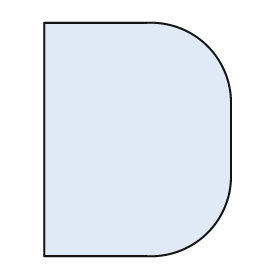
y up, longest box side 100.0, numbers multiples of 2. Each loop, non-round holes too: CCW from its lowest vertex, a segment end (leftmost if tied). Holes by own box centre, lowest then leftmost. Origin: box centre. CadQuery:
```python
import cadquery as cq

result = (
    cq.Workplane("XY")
    .moveTo(-40.0, -50.0)
    .lineTo(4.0, -50.0)
    .threePointArc((30.0, -40.0), (40.0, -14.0))
    .lineTo(40.0, 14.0)
    .threePointArc((30.0, 40.0), (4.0, 50.0))
    .lineTo(-40.0, 50.0)
    .close()
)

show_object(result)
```